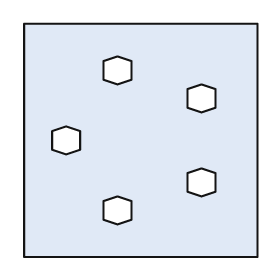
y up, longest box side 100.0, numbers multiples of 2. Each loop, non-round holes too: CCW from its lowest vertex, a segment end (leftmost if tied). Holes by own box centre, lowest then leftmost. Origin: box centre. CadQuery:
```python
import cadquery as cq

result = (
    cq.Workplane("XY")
    .moveTo(-50.0, -50.0)
    .lineTo(50.0, -50.0)
    .lineTo(50.0, 50.0)
    .lineTo(-50.0, 50.0)
    .close()
    .moveTo(-10.0, -36.0)
    .lineTo(-4.0, -34.0)
    .lineTo(-4.0, -26.0)
    .lineTo(-10.0, -24.0)
    .lineTo(-16.0, -26.0)
    .lineTo(-16.0, -34.0)
    .close()
    .moveTo(26.0, -24.0)
    .lineTo(32.0, -22.0)
    .lineTo(32.0, -14.0)
    .lineTo(26.0, -12.0)
    .lineTo(20.0, -14.0)
    .lineTo(20.0, -22.0)
    .close()
    .moveTo(-32.0, -6.0)
    .lineTo(-26.0, -4.0)
    .lineTo(-26.0, 4.0)
    .lineTo(-32.0, 6.0)
    .lineTo(-38.0, 4.0)
    .lineTo(-38.0, -4.0)
    .close()
    .moveTo(26.0, 12.0)
    .lineTo(32.0, 14.0)
    .lineTo(32.0, 22.0)
    .lineTo(26.0, 24.0)
    .lineTo(20.0, 22.0)
    .lineTo(20.0, 14.0)
    .close()
    .moveTo(-10.0, 24.0)
    .lineTo(-4.0, 26.0)
    .lineTo(-4.0, 34.0)
    .lineTo(-10.0, 36.0)
    .lineTo(-16.0, 34.0)
    .lineTo(-16.0, 26.0)
    .close()
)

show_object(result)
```